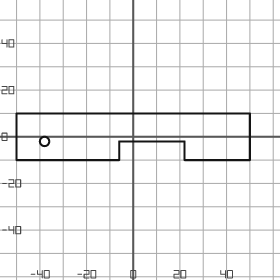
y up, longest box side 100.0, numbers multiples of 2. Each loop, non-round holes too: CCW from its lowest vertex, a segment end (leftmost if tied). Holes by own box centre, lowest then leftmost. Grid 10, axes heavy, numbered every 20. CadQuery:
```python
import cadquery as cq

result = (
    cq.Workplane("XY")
    .moveTo(-50.0, -10.0)
    .lineTo(-6.0, -10.0)
    .lineTo(-6.0, -2.0)
    .lineTo(22.0, -2.0)
    .lineTo(22.0, -10.0)
    .lineTo(50.0, -10.0)
    .lineTo(50.0, 10.0)
    .lineTo(-50.0, 10.0)
    .close()
    .moveTo(-38.0, -2.0)
    .circle(2.0)
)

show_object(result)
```